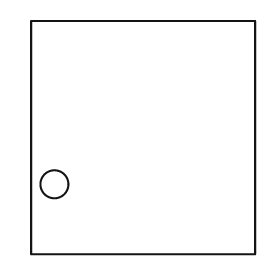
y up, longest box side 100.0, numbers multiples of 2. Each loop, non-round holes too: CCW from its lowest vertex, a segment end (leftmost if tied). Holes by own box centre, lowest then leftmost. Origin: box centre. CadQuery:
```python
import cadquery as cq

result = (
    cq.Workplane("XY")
    .moveTo(-48.0, -50.0)
    .lineTo(48.0, -50.0)
    .lineTo(48.0, 50.0)
    .lineTo(-48.0, 50.0)
    .close()
    .moveTo(-38.0, -20.0)
    .circle(6.0)
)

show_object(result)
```